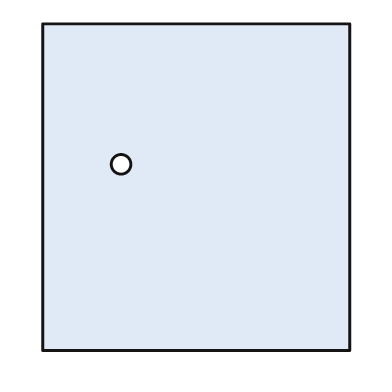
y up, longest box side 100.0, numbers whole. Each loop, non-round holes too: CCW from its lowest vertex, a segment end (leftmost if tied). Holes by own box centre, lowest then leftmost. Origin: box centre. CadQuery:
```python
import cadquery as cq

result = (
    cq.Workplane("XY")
    .moveTo(-47.0, -50.0)
    .lineTo(47.0, -50.0)
    .lineTo(47.0, 50.0)
    .lineTo(-47.0, 50.0)
    .close()
    .moveTo(-23.0, 7.0)
    .circle(3.0)
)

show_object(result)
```